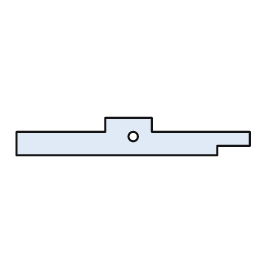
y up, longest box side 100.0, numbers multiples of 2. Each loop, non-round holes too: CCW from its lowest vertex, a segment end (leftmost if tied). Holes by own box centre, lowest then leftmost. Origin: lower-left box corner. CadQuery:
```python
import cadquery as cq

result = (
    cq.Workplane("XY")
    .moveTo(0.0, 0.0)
    .lineTo(86.0, 0.0)
    .lineTo(86.0, 4.0)
    .lineTo(100.0, 4.0)
    .lineTo(100.0, 10.0)
    .lineTo(58.0, 10.0)
    .lineTo(58.0, 16.0)
    .lineTo(38.0, 16.0)
    .lineTo(38.0, 10.0)
    .lineTo(0.0, 10.0)
    .close()
    .moveTo(50.0, 8.0)
    .circle(2.0)
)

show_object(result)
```